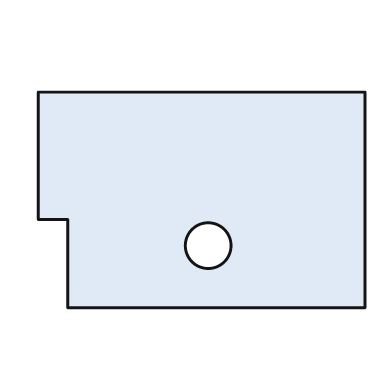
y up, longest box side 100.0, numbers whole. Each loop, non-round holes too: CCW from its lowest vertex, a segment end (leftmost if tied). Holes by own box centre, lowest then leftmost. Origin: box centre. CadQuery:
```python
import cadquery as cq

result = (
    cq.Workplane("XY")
    .moveTo(-41.0, -33.0)
    .lineTo(50.0, -33.0)
    .lineTo(50.0, 33.0)
    .lineTo(-50.0, 33.0)
    .lineTo(-50.0, -6.0)
    .lineTo(-41.0, -6.0)
    .close()
    .moveTo(2.0, -14.0)
    .circle(7.0)
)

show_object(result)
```